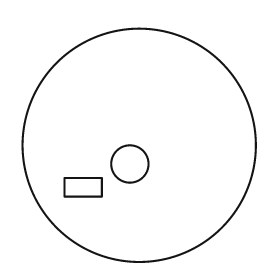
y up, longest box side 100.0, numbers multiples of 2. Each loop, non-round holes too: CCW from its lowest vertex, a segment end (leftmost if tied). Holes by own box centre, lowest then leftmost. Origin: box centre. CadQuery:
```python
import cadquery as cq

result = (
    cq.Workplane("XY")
    .moveTo(0.0, 0.0)
    .circle(50.0)
    .moveTo(-32.0, -22.0)
    .lineTo(-16.0, -22.0)
    .lineTo(-16.0, -14.0)
    .lineTo(-32.0, -14.0)
    .close()
    .moveTo(-4.0, -8.0)
    .circle(8.0)
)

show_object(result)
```